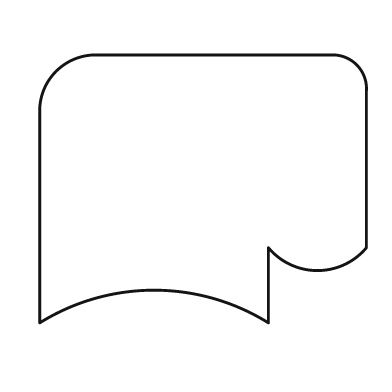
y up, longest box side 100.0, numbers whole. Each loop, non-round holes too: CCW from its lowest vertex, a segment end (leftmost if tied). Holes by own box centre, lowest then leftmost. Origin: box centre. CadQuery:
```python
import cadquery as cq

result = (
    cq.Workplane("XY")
    .moveTo(-50.0, -41.0)
    .threePointArc((-15.0, -31.0), (20.0, -41.0))
    .lineTo(20.0, -18.0)
    .threePointArc((35.0, -25.0), (50.0, -18.0))
    .lineTo(50.0, 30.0)
    .threePointArc((47.0, 38.0), (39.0, 41.0))
    .lineTo(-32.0, 41.0)
    .threePointArc((-45.0, 36.0), (-50.0, 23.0))
    .close()
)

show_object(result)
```